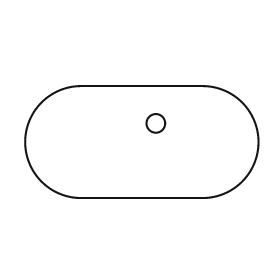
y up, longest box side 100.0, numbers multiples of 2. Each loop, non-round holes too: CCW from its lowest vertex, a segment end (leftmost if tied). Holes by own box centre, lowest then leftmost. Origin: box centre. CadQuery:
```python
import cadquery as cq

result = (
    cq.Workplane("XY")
    .moveTo(-26.0, -24.0)
    .lineTo(26.0, -24.0)
    .threePointArc((50.0, 0.0), (26.0, 24.0))
    .lineTo(-26.0, 24.0)
    .threePointArc((-50.0, 0.0), (-26.0, -24.0))
    .close()
    .moveTo(6.0, 8.0)
    .circle(4.0)
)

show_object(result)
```